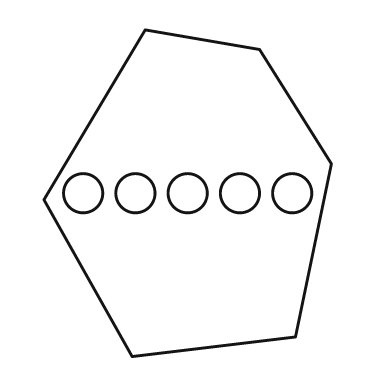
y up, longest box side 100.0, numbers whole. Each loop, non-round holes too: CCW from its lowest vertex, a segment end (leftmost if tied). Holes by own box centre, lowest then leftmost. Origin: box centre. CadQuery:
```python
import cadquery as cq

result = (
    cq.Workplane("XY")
    .moveTo(-17.0, -50.0)
    .lineTo(33.0, -44.0)
    .lineTo(44.0, 9.0)
    .lineTo(22.0, 44.0)
    .lineTo(-13.0, 50.0)
    .lineTo(-44.0, -2.0)
    .close()
    .moveTo(-32.0, 0.0)
    .circle(6.0)
    .moveTo(-16.0, 0.0)
    .circle(6.0)
    .moveTo(0.0, 0.0)
    .circle(6.0)
    .moveTo(16.0, 0.0)
    .circle(6.0)
    .moveTo(32.0, 0.0)
    .circle(6.0)
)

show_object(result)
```